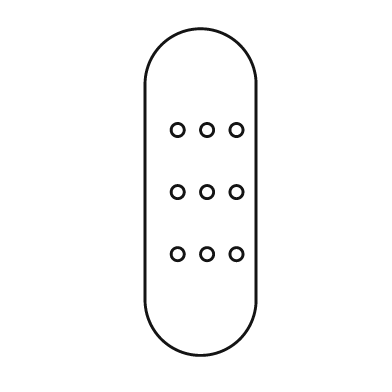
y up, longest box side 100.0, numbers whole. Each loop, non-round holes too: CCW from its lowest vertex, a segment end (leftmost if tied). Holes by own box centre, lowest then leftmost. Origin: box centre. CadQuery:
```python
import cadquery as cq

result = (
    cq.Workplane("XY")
    .moveTo(-17.0, -33.0)
    .threePointArc((0.0, -50.0), (17.0, -33.0))
    .lineTo(17.0, 33.0)
    .threePointArc((0.0, 50.0), (-17.0, 33.0))
    .close()
    .moveTo(-7.0, -19.0)
    .circle(2.0)
    .moveTo(2.0, -19.0)
    .circle(2.0)
    .moveTo(11.0, -19.0)
    .circle(2.0)
    .moveTo(-7.0, 0.0)
    .circle(2.0)
    .moveTo(2.0, 0.0)
    .circle(2.0)
    .moveTo(11.0, 0.0)
    .circle(2.0)
    .moveTo(-7.0, 19.0)
    .circle(2.0)
    .moveTo(2.0, 19.0)
    .circle(2.0)
    .moveTo(11.0, 19.0)
    .circle(2.0)
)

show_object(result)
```